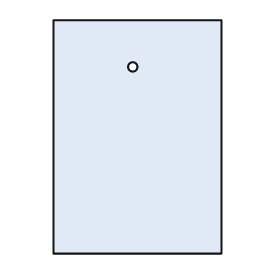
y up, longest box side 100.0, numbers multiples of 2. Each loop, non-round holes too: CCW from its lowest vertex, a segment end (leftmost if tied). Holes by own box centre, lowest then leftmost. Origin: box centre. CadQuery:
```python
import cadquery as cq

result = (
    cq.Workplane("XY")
    .moveTo(-36.0, -50.0)
    .lineTo(36.0, -50.0)
    .lineTo(36.0, 50.0)
    .lineTo(-36.0, 50.0)
    .close()
    .moveTo(-2.0, 30.0)
    .circle(2.0)
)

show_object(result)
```